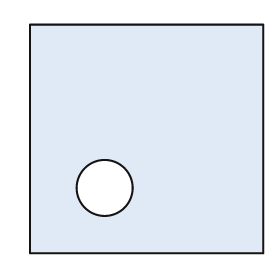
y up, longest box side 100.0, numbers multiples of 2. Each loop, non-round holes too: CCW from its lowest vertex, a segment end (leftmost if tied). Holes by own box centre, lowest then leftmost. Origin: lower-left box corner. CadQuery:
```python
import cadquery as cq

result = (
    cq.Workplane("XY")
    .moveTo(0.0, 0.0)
    .lineTo(100.0, 0.0)
    .lineTo(100.0, 98.0)
    .lineTo(0.0, 98.0)
    .close()
    .moveTo(32.0, 28.0)
    .circle(12.0)
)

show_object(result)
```